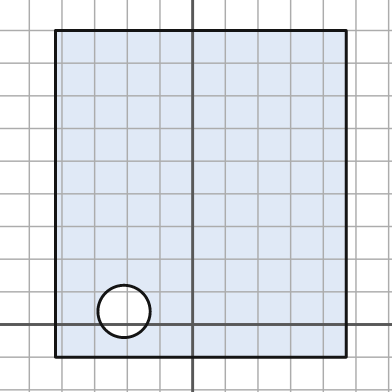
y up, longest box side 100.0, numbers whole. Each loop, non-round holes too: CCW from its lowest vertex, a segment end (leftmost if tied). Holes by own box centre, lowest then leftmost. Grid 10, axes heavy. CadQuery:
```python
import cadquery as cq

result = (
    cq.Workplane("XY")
    .moveTo(-42.0, -10.0)
    .lineTo(47.0, -10.0)
    .lineTo(47.0, 90.0)
    .lineTo(-42.0, 90.0)
    .close()
    .moveTo(-21.0, 4.0)
    .circle(8.0)
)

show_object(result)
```